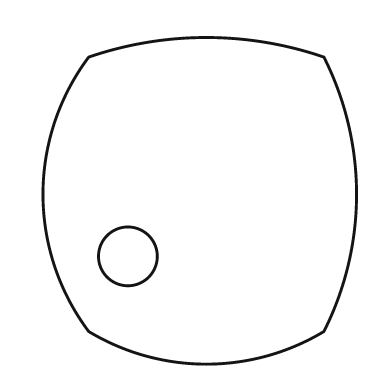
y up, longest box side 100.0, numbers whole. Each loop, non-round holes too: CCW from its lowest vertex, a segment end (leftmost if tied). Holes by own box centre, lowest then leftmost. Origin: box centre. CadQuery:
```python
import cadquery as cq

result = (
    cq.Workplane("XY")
    .moveTo(-34.0, -40.0)
    .threePointArc((2.0, -50.0), (38.0, -40.0))
    .threePointArc((48.0, 2.0), (38.0, 44.0))
    .threePointArc((2.0, 50.0), (-34.0, 44.0))
    .threePointArc((-48.0, 2.0), (-34.0, -40.0))
    .close()
    .moveTo(-22.0, -17.0)
    .circle(9.0)
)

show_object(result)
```